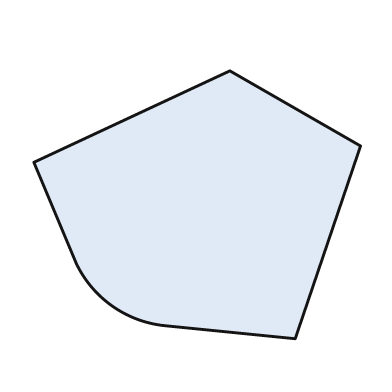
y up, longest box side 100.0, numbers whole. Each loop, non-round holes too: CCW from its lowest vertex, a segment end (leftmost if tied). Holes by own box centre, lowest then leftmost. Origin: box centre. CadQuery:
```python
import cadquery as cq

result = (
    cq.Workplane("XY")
    .moveTo(30.0, -41.0)
    .lineTo(50.0, 18.0)
    .lineTo(10.0, 41.0)
    .lineTo(-50.0, 13.0)
    .lineTo(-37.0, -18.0)
    .threePointArc((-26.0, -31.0), (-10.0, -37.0))
    .close()
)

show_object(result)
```